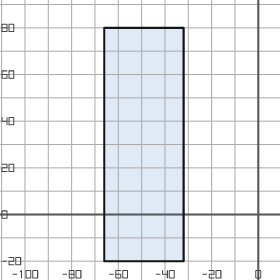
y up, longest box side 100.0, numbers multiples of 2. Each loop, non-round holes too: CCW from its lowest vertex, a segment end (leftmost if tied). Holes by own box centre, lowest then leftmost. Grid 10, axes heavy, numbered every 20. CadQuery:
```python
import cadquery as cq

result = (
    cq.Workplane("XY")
    .moveTo(-66.0, -20.0)
    .lineTo(-32.0, -20.0)
    .lineTo(-32.0, 80.0)
    .lineTo(-66.0, 80.0)
    .close()
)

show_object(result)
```